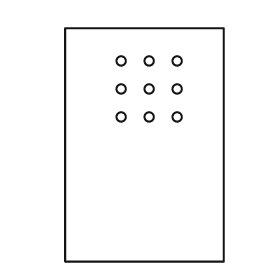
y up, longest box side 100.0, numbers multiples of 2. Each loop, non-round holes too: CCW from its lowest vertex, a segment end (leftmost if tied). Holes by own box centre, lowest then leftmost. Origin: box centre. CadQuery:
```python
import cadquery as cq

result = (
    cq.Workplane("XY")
    .moveTo(-34.0, -50.0)
    .lineTo(34.0, -50.0)
    .lineTo(34.0, 50.0)
    .lineTo(-34.0, 50.0)
    .close()
    .moveTo(-10.0, 12.0)
    .circle(2.0)
    .moveTo(2.0, 12.0)
    .circle(2.0)
    .moveTo(14.0, 12.0)
    .circle(2.0)
    .moveTo(-10.0, 24.0)
    .circle(2.0)
    .moveTo(2.0, 24.0)
    .circle(2.0)
    .moveTo(14.0, 24.0)
    .circle(2.0)
    .moveTo(-10.0, 36.0)
    .circle(2.0)
    .moveTo(2.0, 36.0)
    .circle(2.0)
    .moveTo(14.0, 36.0)
    .circle(2.0)
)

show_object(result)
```